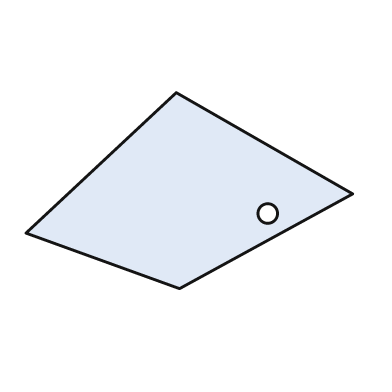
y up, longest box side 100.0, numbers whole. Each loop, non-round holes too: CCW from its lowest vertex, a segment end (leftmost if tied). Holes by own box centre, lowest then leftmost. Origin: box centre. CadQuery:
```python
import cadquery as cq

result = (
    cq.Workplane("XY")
    .moveTo(-3.0, -30.0)
    .lineTo(50.0, -1.0)
    .lineTo(-4.0, 30.0)
    .lineTo(-50.0, -13.0)
    .close()
    .moveTo(24.0, -7.0)
    .circle(3.0)
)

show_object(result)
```